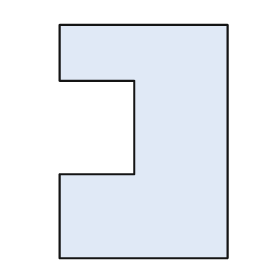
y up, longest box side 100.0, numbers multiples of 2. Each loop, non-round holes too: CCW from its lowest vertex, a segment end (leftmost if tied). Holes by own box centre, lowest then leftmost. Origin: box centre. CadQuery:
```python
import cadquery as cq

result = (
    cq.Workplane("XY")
    .moveTo(-36.0, -50.0)
    .lineTo(36.0, -50.0)
    .lineTo(36.0, 50.0)
    .lineTo(-36.0, 50.0)
    .lineTo(-36.0, 26.0)
    .lineTo(-4.0, 26.0)
    .lineTo(-4.0, -14.0)
    .lineTo(-36.0, -14.0)
    .close()
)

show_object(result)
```